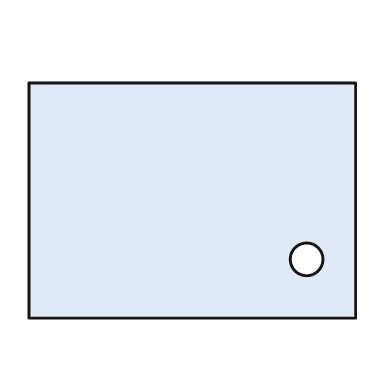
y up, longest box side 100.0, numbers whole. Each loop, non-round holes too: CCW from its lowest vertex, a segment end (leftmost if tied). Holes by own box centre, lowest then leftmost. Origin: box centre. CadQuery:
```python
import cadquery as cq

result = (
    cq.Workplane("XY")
    .moveTo(-50.0, -36.0)
    .lineTo(50.0, -36.0)
    .lineTo(50.0, 36.0)
    .lineTo(-50.0, 36.0)
    .close()
    .moveTo(35.0, -18.0)
    .circle(5.0)
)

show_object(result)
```